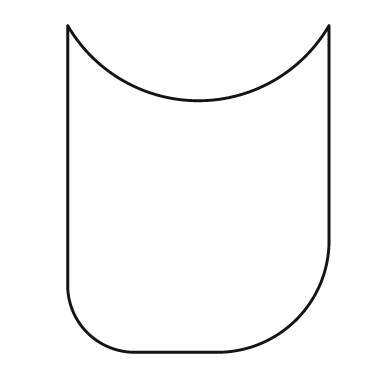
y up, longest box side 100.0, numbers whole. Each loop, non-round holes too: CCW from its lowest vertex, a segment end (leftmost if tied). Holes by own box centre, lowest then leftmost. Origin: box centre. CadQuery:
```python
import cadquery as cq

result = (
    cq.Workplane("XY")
    .moveTo(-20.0, -50.0)
    .lineTo(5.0, -50.0)
    .threePointArc((30.0, -40.0), (40.0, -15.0))
    .lineTo(40.0, 50.0)
    .threePointArc((0.0, 27.0), (-40.0, 50.0))
    .lineTo(-40.0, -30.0)
    .threePointArc((-34.0, -44.0), (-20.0, -50.0))
    .close()
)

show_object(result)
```